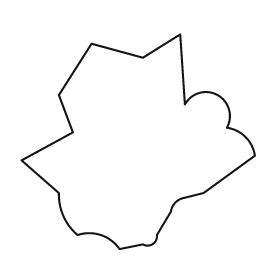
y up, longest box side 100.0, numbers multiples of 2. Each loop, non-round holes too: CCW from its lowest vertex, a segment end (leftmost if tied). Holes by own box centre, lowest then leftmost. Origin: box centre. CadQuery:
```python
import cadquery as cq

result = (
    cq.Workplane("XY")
    .moveTo(-8.0, -46.0)
    .lineTo(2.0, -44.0)
    .threePointArc((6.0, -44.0), (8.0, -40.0))
    .lineTo(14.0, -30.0)
    .threePointArc((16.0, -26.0), (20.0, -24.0))
    .lineTo(28.0, -22.0)
    .lineTo(50.0, -6.0)
    .threePointArc((46.0, 2.0), (38.0, 6.0))
    .threePointArc((34.0, 20.0), (20.0, 16.0))
    .lineTo(18.0, 46.0)
    .lineTo(2.0, 36.0)
    .lineTo(-20.0, 42.0)
    .lineTo(-34.0, 20.0)
    .lineTo(-28.0, 4.0)
    .lineTo(-50.0, -8.0)
    .lineTo(-34.0, -22.0)
    .threePointArc((-32.0, -32.0), (-26.0, -40.0))
    .threePointArc((-16.0, -40.0), (-8.0, -46.0))
    .close()
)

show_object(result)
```